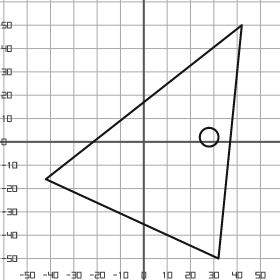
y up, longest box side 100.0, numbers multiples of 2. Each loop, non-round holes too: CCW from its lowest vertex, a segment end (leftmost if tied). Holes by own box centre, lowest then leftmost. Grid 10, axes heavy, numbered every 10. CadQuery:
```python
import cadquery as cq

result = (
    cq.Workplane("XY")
    .moveTo(32.0, -50.0)
    .lineTo(42.0, 50.0)
    .lineTo(-42.0, -16.0)
    .close()
    .moveTo(28.0, 2.0)
    .circle(4.0)
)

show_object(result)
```